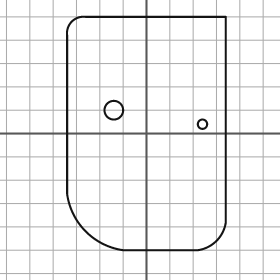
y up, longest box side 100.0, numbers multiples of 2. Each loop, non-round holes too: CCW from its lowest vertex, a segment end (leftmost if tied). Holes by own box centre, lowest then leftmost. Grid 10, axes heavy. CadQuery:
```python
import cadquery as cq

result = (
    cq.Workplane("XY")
    .moveTo(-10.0, -50.0)
    .lineTo(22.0, -50.0)
    .threePointArc((30.0, -46.0), (34.0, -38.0))
    .lineTo(34.0, 50.0)
    .lineTo(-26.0, 50.0)
    .threePointArc((-32.0, 48.0), (-34.0, 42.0))
    .lineTo(-34.0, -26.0)
    .threePointArc((-26.0, -42.0), (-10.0, -50.0))
    .close()
    .moveTo(24.0, 4.0)
    .circle(2.0)
    .moveTo(-14.0, 10.0)
    .circle(4.0)
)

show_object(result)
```